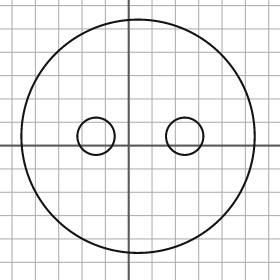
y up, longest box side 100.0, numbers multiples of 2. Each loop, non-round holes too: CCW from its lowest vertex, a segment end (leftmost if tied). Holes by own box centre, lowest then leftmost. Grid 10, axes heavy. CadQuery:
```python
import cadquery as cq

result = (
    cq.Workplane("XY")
    .moveTo(4.0, 4.0)
    .circle(50.0)
    .moveTo(-14.0, 4.0)
    .circle(8.0)
    .moveTo(24.0, 4.0)
    .circle(8.0)
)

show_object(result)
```